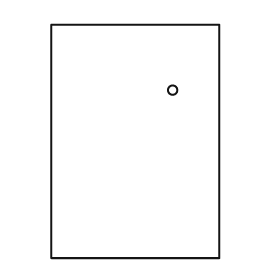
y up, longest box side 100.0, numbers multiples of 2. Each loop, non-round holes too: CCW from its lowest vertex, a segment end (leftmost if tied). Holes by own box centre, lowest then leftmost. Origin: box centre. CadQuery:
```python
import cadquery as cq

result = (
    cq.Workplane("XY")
    .moveTo(-36.0, -50.0)
    .lineTo(36.0, -50.0)
    .lineTo(36.0, 50.0)
    .lineTo(-36.0, 50.0)
    .close()
    .moveTo(16.0, 22.0)
    .circle(2.0)
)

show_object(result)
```